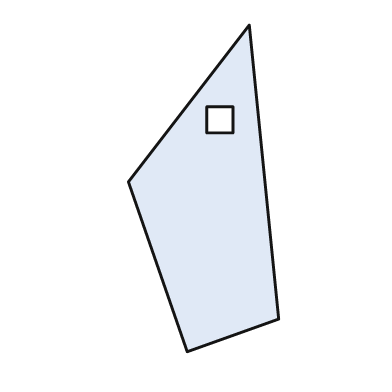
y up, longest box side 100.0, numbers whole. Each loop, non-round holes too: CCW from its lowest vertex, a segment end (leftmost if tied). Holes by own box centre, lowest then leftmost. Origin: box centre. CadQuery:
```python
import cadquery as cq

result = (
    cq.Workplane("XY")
    .moveTo(-5.0, -50.0)
    .lineTo(23.0, -40.0)
    .lineTo(14.0, 50.0)
    .lineTo(-23.0, 2.0)
    .close()
    .moveTo(1.0, 17.0)
    .lineTo(9.0, 17.0)
    .lineTo(9.0, 25.0)
    .lineTo(1.0, 25.0)
    .close()
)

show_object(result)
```